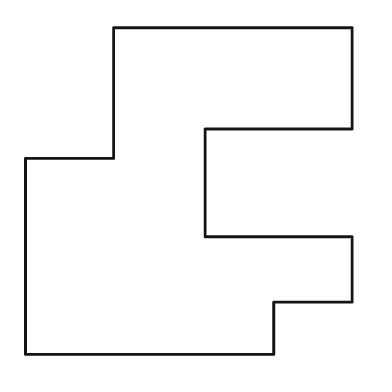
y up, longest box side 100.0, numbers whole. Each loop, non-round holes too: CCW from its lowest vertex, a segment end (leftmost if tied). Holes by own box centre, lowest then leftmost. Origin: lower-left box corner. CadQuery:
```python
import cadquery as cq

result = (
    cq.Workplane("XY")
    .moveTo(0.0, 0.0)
    .lineTo(76.0, 0.0)
    .lineTo(76.0, 16.0)
    .lineTo(100.0, 16.0)
    .lineTo(100.0, 36.0)
    .lineTo(55.0, 36.0)
    .lineTo(55.0, 69.0)
    .lineTo(100.0, 69.0)
    .lineTo(100.0, 100.0)
    .lineTo(27.0, 100.0)
    .lineTo(27.0, 60.0)
    .lineTo(0.0, 60.0)
    .close()
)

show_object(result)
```